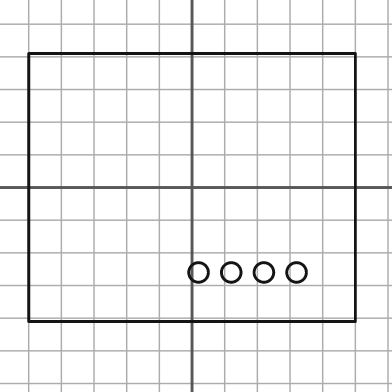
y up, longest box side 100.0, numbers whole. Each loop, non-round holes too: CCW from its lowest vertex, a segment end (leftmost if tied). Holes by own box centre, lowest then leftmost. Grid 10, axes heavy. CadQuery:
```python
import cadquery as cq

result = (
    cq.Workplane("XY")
    .moveTo(-50.0, -41.0)
    .lineTo(50.0, -41.0)
    .lineTo(50.0, 41.0)
    .lineTo(-50.0, 41.0)
    .close()
    .moveTo(2.0, -26.0)
    .circle(3.0)
    .moveTo(12.0, -26.0)
    .circle(3.0)
    .moveTo(22.0, -26.0)
    .circle(3.0)
    .moveTo(32.0, -26.0)
    .circle(3.0)
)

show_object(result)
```